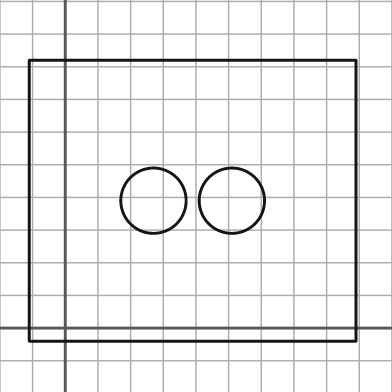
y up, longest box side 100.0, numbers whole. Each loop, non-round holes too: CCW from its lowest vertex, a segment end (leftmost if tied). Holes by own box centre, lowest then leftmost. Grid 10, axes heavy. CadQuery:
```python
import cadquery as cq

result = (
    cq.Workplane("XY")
    .moveTo(-11.0, -4.0)
    .lineTo(89.0, -4.0)
    .lineTo(89.0, 82.0)
    .lineTo(-11.0, 82.0)
    .close()
    .moveTo(27.0, 39.0)
    .circle(10.0)
    .moveTo(51.0, 39.0)
    .circle(10.0)
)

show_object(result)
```